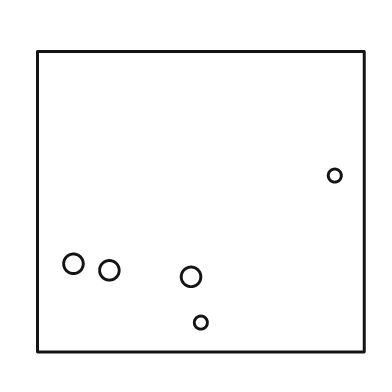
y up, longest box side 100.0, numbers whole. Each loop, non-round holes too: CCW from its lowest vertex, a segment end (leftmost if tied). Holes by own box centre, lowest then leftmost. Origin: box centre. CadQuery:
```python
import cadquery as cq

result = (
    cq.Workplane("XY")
    .moveTo(-50.0, -46.0)
    .lineTo(50.0, -46.0)
    .lineTo(50.0, 46.0)
    .lineTo(-50.0, 46.0)
    .close()
    .moveTo(0.0, -37.0)
    .circle(2.0)
    .moveTo(-3.0, -23.0)
    .circle(3.0)
    .moveTo(-28.0, -21.0)
    .circle(3.0)
    .moveTo(-39.0, -19.0)
    .circle(3.0)
    .moveTo(41.0, 8.0)
    .circle(2.0)
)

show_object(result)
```